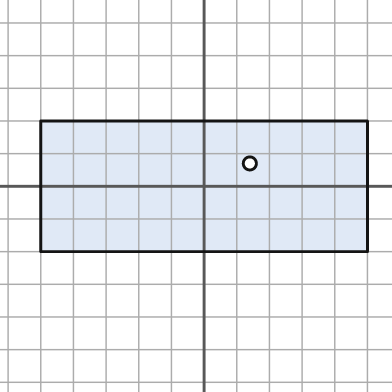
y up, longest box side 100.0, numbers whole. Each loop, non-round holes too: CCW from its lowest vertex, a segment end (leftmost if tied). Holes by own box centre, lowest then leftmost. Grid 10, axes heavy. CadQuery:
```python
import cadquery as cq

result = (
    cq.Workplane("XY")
    .moveTo(-50.0, -20.0)
    .lineTo(50.0, -20.0)
    .lineTo(50.0, 20.0)
    .lineTo(-50.0, 20.0)
    .close()
    .moveTo(14.0, 7.0)
    .circle(2.0)
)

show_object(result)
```